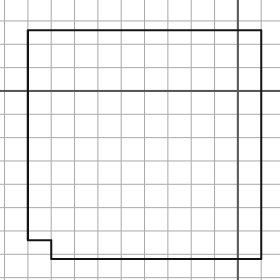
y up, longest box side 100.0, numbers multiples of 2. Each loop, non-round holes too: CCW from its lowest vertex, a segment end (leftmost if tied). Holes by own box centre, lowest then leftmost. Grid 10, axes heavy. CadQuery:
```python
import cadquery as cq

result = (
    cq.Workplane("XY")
    .moveTo(-80.0, -72.0)
    .lineTo(10.0, -72.0)
    .lineTo(10.0, 26.0)
    .lineTo(-90.0, 26.0)
    .lineTo(-90.0, -64.0)
    .lineTo(-80.0, -64.0)
    .close()
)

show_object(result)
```